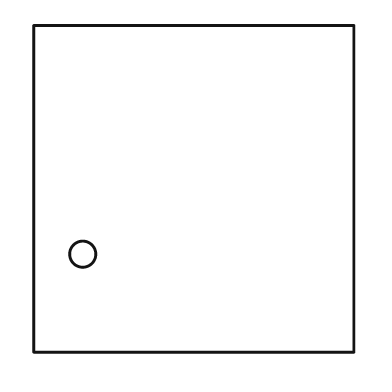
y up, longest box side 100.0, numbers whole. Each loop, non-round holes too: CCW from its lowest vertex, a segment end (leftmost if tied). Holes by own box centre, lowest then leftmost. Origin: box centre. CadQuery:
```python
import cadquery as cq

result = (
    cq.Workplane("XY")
    .moveTo(-49.0, -50.0)
    .lineTo(49.0, -50.0)
    .lineTo(49.0, 50.0)
    .lineTo(-49.0, 50.0)
    .close()
    .moveTo(-34.0, -20.0)
    .circle(4.0)
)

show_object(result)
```